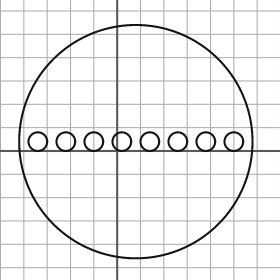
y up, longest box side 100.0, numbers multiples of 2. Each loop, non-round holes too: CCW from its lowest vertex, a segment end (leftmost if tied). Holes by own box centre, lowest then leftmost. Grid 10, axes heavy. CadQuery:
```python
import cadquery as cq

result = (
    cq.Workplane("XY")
    .moveTo(8.0, 4.0)
    .circle(50.0)
    .moveTo(-34.0, 4.0)
    .circle(4.0)
    .moveTo(-22.0, 4.0)
    .circle(4.0)
    .moveTo(-10.0, 4.0)
    .circle(4.0)
    .moveTo(2.0, 4.0)
    .circle(4.0)
    .moveTo(14.0, 4.0)
    .circle(4.0)
    .moveTo(26.0, 4.0)
    .circle(4.0)
    .moveTo(38.0, 4.0)
    .circle(4.0)
    .moveTo(50.0, 4.0)
    .circle(4.0)
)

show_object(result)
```